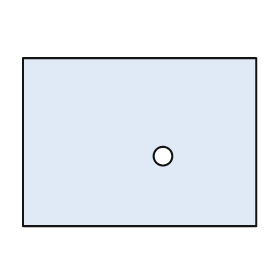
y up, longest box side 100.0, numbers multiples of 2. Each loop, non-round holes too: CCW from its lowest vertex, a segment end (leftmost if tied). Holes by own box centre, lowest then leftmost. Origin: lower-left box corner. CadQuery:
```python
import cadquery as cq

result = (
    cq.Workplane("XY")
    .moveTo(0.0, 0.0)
    .lineTo(100.0, 0.0)
    .lineTo(100.0, 72.0)
    .lineTo(0.0, 72.0)
    .close()
    .moveTo(60.0, 30.0)
    .circle(4.0)
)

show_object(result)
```